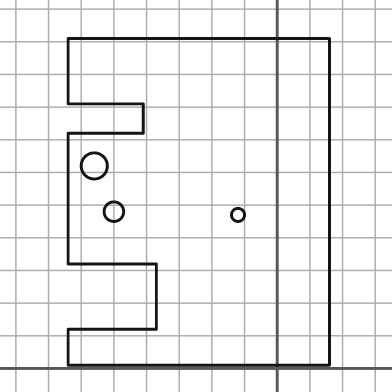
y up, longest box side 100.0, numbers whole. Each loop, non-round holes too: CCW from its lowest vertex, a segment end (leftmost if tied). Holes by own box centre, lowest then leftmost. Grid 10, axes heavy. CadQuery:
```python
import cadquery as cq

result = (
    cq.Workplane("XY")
    .moveTo(-64.0, 1.0)
    .lineTo(16.0, 1.0)
    .lineTo(16.0, 101.0)
    .lineTo(-64.0, 101.0)
    .lineTo(-64.0, 81.0)
    .lineTo(-41.0, 81.0)
    .lineTo(-41.0, 72.0)
    .lineTo(-64.0, 72.0)
    .lineTo(-64.0, 32.0)
    .lineTo(-37.0, 32.0)
    .lineTo(-37.0, 12.0)
    .lineTo(-64.0, 12.0)
    .close()
    .moveTo(-12.0, 47.0)
    .circle(2.0)
    .moveTo(-50.0, 48.0)
    .circle(3.0)
    .moveTo(-56.0, 62.0)
    .circle(4.0)
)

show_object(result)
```